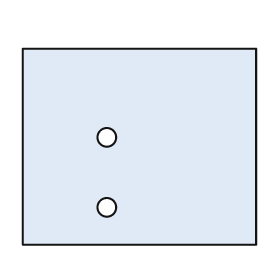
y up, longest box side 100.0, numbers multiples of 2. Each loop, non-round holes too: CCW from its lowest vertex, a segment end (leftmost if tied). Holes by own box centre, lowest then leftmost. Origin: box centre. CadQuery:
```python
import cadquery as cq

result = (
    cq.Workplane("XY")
    .moveTo(-50.0, -42.0)
    .lineTo(50.0, -42.0)
    .lineTo(50.0, 42.0)
    .lineTo(-50.0, 42.0)
    .close()
    .moveTo(-14.0, -26.0)
    .circle(4.0)
    .moveTo(-14.0, 4.0)
    .circle(4.0)
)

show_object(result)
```